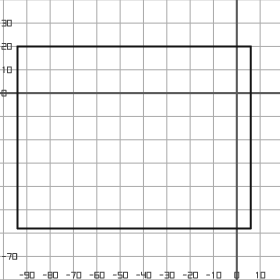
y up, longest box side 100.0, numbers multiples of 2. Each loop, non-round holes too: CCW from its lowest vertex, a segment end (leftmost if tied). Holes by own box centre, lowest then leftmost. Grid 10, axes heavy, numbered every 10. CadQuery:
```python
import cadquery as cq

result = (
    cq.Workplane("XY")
    .moveTo(-94.0, -58.0)
    .lineTo(6.0, -58.0)
    .lineTo(6.0, 20.0)
    .lineTo(-94.0, 20.0)
    .close()
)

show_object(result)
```